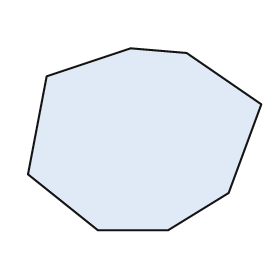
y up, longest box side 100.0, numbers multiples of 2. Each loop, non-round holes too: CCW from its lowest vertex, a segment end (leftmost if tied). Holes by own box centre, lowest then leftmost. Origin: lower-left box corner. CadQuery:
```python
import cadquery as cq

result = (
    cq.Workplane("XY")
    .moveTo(30.0, 0.0)
    .lineTo(60.0, 0.0)
    .lineTo(86.0, 16.0)
    .lineTo(100.0, 54.0)
    .lineTo(68.0, 76.0)
    .lineTo(44.0, 78.0)
    .lineTo(8.0, 66.0)
    .lineTo(0.0, 24.0)
    .close()
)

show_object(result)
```